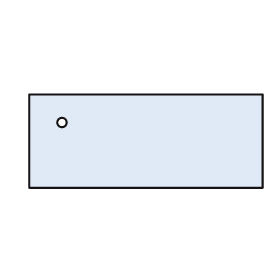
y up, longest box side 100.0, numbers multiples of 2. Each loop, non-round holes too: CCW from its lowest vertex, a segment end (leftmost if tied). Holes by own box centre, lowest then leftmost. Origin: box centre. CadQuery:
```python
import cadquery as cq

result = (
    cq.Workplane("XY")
    .moveTo(-50.0, -20.0)
    .lineTo(50.0, -20.0)
    .lineTo(50.0, 20.0)
    .lineTo(-50.0, 20.0)
    .close()
    .moveTo(-36.0, 8.0)
    .circle(2.0)
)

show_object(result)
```